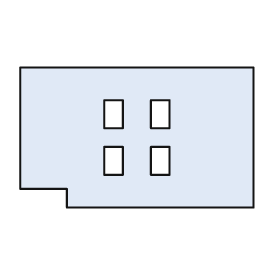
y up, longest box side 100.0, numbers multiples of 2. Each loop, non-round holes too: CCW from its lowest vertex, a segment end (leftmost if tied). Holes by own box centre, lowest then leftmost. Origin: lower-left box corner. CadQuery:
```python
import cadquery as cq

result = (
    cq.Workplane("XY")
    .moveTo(20.0, 0.0)
    .lineTo(100.0, 0.0)
    .lineTo(100.0, 60.0)
    .lineTo(0.0, 60.0)
    .lineTo(0.0, 8.0)
    .lineTo(20.0, 8.0)
    .close()
    .moveTo(36.0, 14.0)
    .lineTo(44.0, 14.0)
    .lineTo(44.0, 26.0)
    .lineTo(36.0, 26.0)
    .close()
    .moveTo(56.0, 14.0)
    .lineTo(64.0, 14.0)
    .lineTo(64.0, 26.0)
    .lineTo(56.0, 26.0)
    .close()
    .moveTo(36.0, 34.0)
    .lineTo(44.0, 34.0)
    .lineTo(44.0, 46.0)
    .lineTo(36.0, 46.0)
    .close()
    .moveTo(56.0, 34.0)
    .lineTo(64.0, 34.0)
    .lineTo(64.0, 46.0)
    .lineTo(56.0, 46.0)
    .close()
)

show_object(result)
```